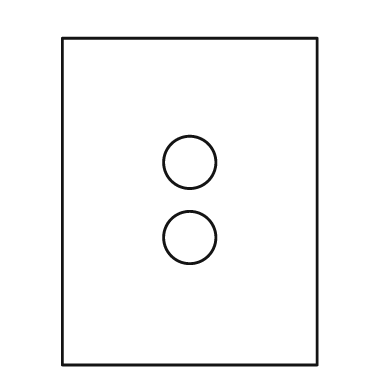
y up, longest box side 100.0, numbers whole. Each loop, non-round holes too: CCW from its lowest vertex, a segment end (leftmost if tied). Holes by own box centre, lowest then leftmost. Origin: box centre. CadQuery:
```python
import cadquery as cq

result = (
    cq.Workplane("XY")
    .moveTo(-39.0, -50.0)
    .lineTo(39.0, -50.0)
    .lineTo(39.0, 50.0)
    .lineTo(-39.0, 50.0)
    .close()
    .moveTo(0.0, -11.0)
    .circle(8.0)
    .moveTo(0.0, 12.0)
    .circle(8.0)
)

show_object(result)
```